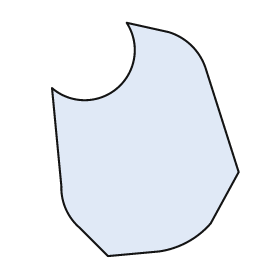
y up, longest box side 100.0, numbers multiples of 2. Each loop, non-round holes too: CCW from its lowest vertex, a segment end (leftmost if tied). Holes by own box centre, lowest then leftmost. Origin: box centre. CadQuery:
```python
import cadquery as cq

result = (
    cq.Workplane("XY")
    .moveTo(-16.0, -50.0)
    .lineTo(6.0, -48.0)
    .threePointArc((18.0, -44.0), (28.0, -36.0))
    .lineTo(40.0, -14.0)
    .lineTo(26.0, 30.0)
    .threePointArc((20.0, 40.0), (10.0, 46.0))
    .lineTo(-8.0, 50.0)
    .threePointArc((-12.0, 22.0), (-40.0, 22.0))
    .lineTo(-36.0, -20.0)
    .threePointArc((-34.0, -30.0), (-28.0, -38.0))
    .close()
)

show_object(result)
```